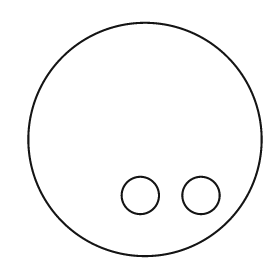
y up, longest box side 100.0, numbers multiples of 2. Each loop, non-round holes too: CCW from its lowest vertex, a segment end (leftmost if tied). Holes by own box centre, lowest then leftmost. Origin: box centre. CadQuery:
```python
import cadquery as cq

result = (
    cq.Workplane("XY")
    .moveTo(0.0, 0.0)
    .circle(50.0)
    .moveTo(-2.0, -24.0)
    .circle(8.0)
    .moveTo(24.0, -24.0)
    .circle(8.0)
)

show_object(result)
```